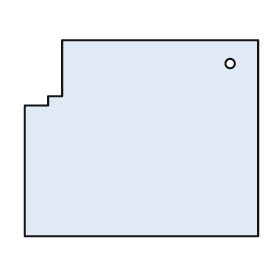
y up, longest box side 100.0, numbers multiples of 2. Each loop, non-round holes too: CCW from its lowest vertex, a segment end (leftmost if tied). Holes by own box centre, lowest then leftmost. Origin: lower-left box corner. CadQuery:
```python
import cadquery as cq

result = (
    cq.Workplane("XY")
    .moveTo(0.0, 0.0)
    .lineTo(100.0, 0.0)
    .lineTo(100.0, 84.0)
    .lineTo(16.0, 84.0)
    .lineTo(16.0, 60.0)
    .lineTo(10.0, 60.0)
    .lineTo(10.0, 56.0)
    .lineTo(0.0, 56.0)
    .close()
    .moveTo(88.0, 74.0)
    .circle(2.0)
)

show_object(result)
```